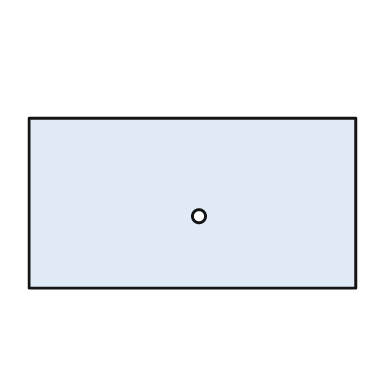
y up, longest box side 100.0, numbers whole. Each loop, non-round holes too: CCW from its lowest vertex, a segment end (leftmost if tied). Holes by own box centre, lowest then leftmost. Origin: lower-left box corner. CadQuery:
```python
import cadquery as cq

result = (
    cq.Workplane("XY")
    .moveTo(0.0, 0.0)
    .lineTo(100.0, 0.0)
    .lineTo(100.0, 52.0)
    .lineTo(0.0, 52.0)
    .close()
    .moveTo(52.0, 22.0)
    .circle(2.0)
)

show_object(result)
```